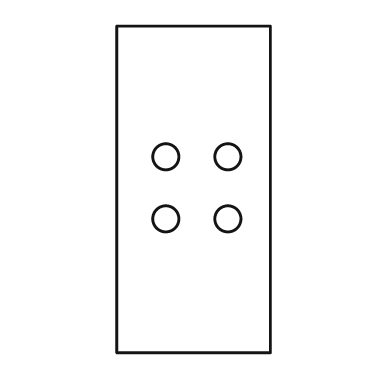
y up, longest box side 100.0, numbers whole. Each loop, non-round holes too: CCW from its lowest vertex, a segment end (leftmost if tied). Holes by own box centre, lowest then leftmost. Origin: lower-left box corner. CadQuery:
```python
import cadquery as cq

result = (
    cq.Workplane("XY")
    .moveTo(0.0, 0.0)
    .lineTo(47.0, 0.0)
    .lineTo(47.0, 100.0)
    .lineTo(0.0, 100.0)
    .close()
    .moveTo(15.0, 41.0)
    .circle(4.0)
    .moveTo(34.0, 41.0)
    .circle(4.0)
    .moveTo(15.0, 60.0)
    .circle(4.0)
    .moveTo(34.0, 60.0)
    .circle(4.0)
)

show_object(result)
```